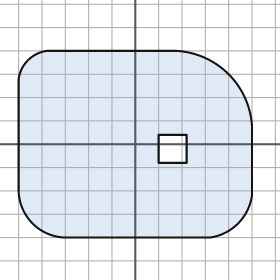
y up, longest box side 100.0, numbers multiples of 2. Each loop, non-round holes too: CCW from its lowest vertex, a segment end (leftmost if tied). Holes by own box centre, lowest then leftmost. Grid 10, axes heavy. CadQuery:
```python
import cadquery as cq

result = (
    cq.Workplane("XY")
    .moveTo(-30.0, -40.0)
    .lineTo(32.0, -40.0)
    .threePointArc((44.0, -34.0), (50.0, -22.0))
    .lineTo(50.0, 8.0)
    .threePointArc((40.0, 30.0), (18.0, 40.0))
    .lineTo(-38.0, 40.0)
    .threePointArc((-46.0, 36.0), (-50.0, 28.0))
    .lineTo(-50.0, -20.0)
    .threePointArc((-44.0, -34.0), (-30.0, -40.0))
    .close()
    .moveTo(10.0, -8.0)
    .lineTo(22.0, -8.0)
    .lineTo(22.0, 4.0)
    .lineTo(10.0, 4.0)
    .close()
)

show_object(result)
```